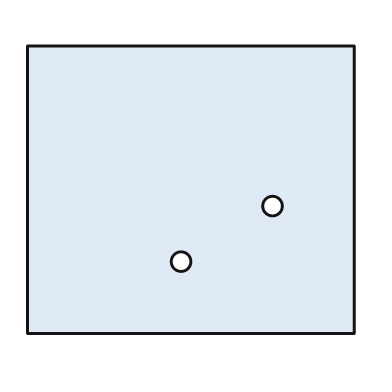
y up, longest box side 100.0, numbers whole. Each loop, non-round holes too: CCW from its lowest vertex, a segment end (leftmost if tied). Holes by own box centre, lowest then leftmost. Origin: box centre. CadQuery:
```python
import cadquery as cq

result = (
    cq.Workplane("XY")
    .moveTo(-50.0, -44.0)
    .lineTo(50.0, -44.0)
    .lineTo(50.0, 44.0)
    .lineTo(-50.0, 44.0)
    .close()
    .moveTo(-3.0, -22.0)
    .circle(3.0)
    .moveTo(25.0, -5.0)
    .circle(3.0)
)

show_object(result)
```